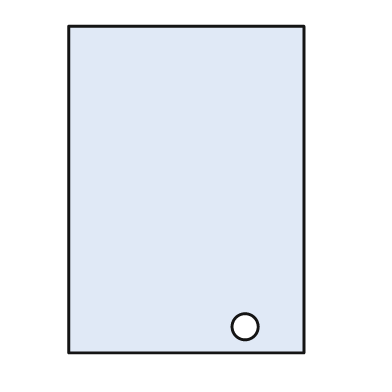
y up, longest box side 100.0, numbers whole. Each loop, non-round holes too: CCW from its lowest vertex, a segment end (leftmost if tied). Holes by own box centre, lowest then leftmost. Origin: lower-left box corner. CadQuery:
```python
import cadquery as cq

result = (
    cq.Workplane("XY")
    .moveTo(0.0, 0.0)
    .lineTo(72.0, 0.0)
    .lineTo(72.0, 100.0)
    .lineTo(0.0, 100.0)
    .close()
    .moveTo(54.0, 8.0)
    .circle(4.0)
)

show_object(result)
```